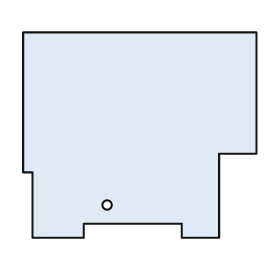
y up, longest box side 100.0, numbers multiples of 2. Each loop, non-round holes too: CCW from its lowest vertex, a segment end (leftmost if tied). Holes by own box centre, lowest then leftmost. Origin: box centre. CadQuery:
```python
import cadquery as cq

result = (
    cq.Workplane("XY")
    .moveTo(-46.0, -44.0)
    .lineTo(-24.0, -44.0)
    .lineTo(-24.0, -38.0)
    .lineTo(18.0, -38.0)
    .lineTo(18.0, -44.0)
    .lineTo(34.0, -44.0)
    .lineTo(34.0, -8.0)
    .lineTo(50.0, -8.0)
    .lineTo(50.0, 44.0)
    .lineTo(-50.0, 44.0)
    .lineTo(-50.0, -16.0)
    .lineTo(-46.0, -16.0)
    .close()
    .moveTo(-14.0, -30.0)
    .circle(2.0)
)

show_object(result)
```